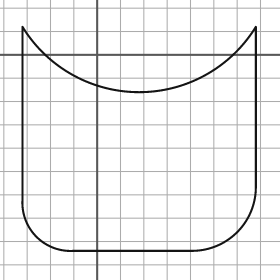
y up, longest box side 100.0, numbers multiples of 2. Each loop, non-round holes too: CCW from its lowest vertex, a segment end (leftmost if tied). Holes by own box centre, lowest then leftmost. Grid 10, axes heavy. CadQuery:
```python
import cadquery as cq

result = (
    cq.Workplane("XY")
    .moveTo(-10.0, -84.0)
    .lineTo(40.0, -84.0)
    .threePointArc((60.0, -76.0), (68.0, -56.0))
    .lineTo(68.0, 12.0)
    .threePointArc((18.0, -16.0), (-32.0, 12.0))
    .lineTo(-32.0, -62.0)
    .threePointArc((-26.0, -78.0), (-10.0, -84.0))
    .close()
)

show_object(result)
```